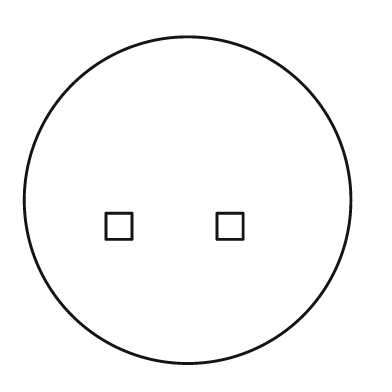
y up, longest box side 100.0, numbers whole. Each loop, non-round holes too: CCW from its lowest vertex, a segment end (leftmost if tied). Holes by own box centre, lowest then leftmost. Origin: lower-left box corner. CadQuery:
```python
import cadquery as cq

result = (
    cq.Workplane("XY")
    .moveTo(50.0, 50.0)
    .circle(50.0)
    .moveTo(25.0, 38.0)
    .lineTo(33.0, 38.0)
    .lineTo(33.0, 46.0)
    .lineTo(25.0, 46.0)
    .close()
    .moveTo(59.0, 38.0)
    .lineTo(67.0, 38.0)
    .lineTo(67.0, 46.0)
    .lineTo(59.0, 46.0)
    .close()
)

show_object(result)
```